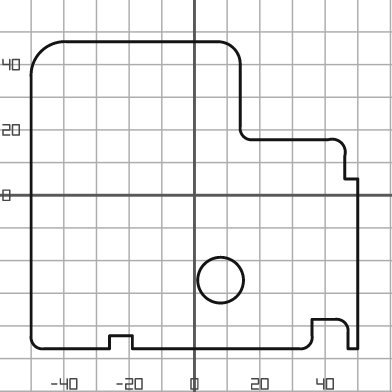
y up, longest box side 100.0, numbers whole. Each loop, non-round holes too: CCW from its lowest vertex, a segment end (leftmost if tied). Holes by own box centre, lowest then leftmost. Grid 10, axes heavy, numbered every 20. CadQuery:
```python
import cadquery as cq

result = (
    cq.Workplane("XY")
    .moveTo(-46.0, -47.0)
    .lineTo(-26.0, -47.0)
    .lineTo(-26.0, -43.0)
    .lineTo(-19.0, -43.0)
    .lineTo(-19.0, -47.0)
    .lineTo(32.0, -47.0)
    .threePointArc((35.0, -46.0), (36.0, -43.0))
    .lineTo(36.0, -38.0)
    .lineTo(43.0, -38.0)
    .threePointArc((46.0, -39.0), (47.0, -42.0))
    .lineTo(47.0, -47.0)
    .lineTo(50.0, -47.0)
    .lineTo(50.0, 5.0)
    .lineTo(46.0, 5.0)
    .lineTo(46.0, 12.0)
    .threePointArc((45.0, 16.0), (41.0, 17.0))
    .lineTo(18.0, 17.0)
    .threePointArc((15.0, 18.0), (14.0, 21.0))
    .lineTo(14.0, 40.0)
    .threePointArc((12.0, 45.0), (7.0, 47.0))
    .lineTo(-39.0, 47.0)
    .threePointArc((-47.0, 44.0), (-50.0, 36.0))
    .lineTo(-50.0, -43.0)
    .threePointArc((-49.0, -46.0), (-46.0, -47.0))
    .close()
    .moveTo(8.0, -26.0)
    .circle(7.0)
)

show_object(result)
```